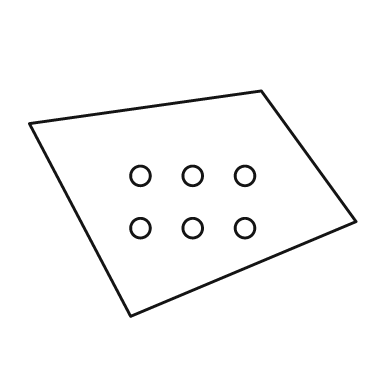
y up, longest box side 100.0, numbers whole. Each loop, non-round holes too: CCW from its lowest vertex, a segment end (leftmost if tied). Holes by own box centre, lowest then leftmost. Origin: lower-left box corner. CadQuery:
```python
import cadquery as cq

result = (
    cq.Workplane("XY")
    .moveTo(31.0, 0.0)
    .lineTo(100.0, 29.0)
    .lineTo(71.0, 69.0)
    .lineTo(0.0, 59.0)
    .close()
    .moveTo(34.0, 27.0)
    .circle(3.0)
    .moveTo(50.0, 27.0)
    .circle(3.0)
    .moveTo(66.0, 27.0)
    .circle(3.0)
    .moveTo(34.0, 43.0)
    .circle(3.0)
    .moveTo(50.0, 43.0)
    .circle(3.0)
    .moveTo(66.0, 43.0)
    .circle(3.0)
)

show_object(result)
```